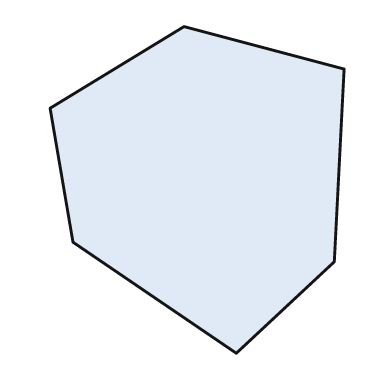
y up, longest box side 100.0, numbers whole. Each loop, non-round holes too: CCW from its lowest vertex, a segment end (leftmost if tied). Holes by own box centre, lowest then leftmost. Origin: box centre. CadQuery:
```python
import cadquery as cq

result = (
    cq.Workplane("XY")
    .moveTo(12.0, -50.0)
    .lineTo(42.0, -22.0)
    .lineTo(45.0, 37.0)
    .lineTo(-4.0, 50.0)
    .lineTo(-45.0, 25.0)
    .lineTo(-38.0, -16.0)
    .close()
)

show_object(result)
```